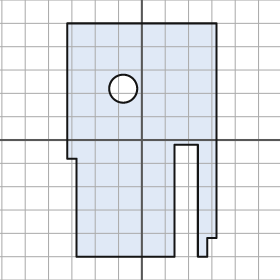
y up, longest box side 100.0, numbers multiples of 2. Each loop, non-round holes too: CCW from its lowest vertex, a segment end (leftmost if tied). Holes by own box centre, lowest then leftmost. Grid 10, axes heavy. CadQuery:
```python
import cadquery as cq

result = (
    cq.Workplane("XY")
    .moveTo(-28.0, -50.0)
    .lineTo(14.0, -50.0)
    .lineTo(14.0, -2.0)
    .lineTo(24.0, -2.0)
    .lineTo(24.0, -50.0)
    .lineTo(28.0, -50.0)
    .lineTo(28.0, -42.0)
    .lineTo(32.0, -42.0)
    .lineTo(32.0, 50.0)
    .lineTo(-32.0, 50.0)
    .lineTo(-32.0, -8.0)
    .lineTo(-28.0, -8.0)
    .close()
    .moveTo(-8.0, 22.0)
    .circle(6.0)
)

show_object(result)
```